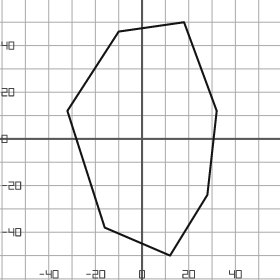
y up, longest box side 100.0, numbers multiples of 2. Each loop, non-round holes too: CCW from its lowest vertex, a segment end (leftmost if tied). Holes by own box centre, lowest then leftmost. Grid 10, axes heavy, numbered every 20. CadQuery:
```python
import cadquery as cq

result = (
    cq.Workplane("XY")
    .moveTo(12.0, -50.0)
    .lineTo(28.0, -24.0)
    .lineTo(32.0, 12.0)
    .lineTo(18.0, 50.0)
    .lineTo(-10.0, 46.0)
    .lineTo(-32.0, 12.0)
    .lineTo(-16.0, -38.0)
    .close()
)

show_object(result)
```